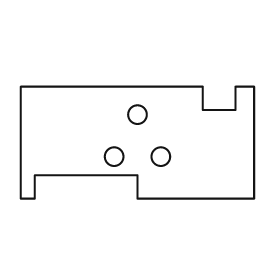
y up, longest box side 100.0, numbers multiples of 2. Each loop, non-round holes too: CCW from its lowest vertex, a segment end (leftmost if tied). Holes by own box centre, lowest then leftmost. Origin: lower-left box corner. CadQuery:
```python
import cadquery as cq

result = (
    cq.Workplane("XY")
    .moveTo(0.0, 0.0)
    .lineTo(6.0, 0.0)
    .lineTo(6.0, 10.0)
    .lineTo(50.0, 10.0)
    .lineTo(50.0, 0.0)
    .lineTo(100.0, 0.0)
    .lineTo(100.0, 48.0)
    .lineTo(92.0, 48.0)
    .lineTo(92.0, 38.0)
    .lineTo(78.0, 38.0)
    .lineTo(78.0, 48.0)
    .lineTo(0.0, 48.0)
    .close()
    .moveTo(40.0, 18.0)
    .circle(4.0)
    .moveTo(60.0, 18.0)
    .circle(4.0)
    .moveTo(50.0, 36.0)
    .circle(4.0)
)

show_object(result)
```